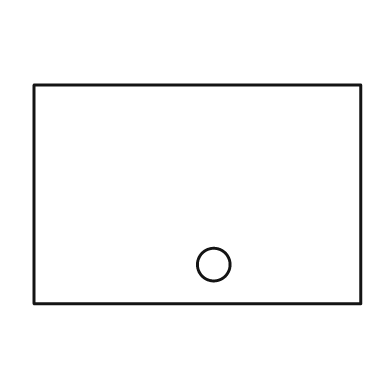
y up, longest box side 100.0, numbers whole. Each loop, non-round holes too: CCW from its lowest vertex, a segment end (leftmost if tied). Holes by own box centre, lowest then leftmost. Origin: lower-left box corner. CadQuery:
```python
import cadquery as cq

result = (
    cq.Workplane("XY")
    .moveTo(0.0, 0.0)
    .lineTo(100.0, 0.0)
    .lineTo(100.0, 67.0)
    .lineTo(0.0, 67.0)
    .close()
    .moveTo(55.0, 12.0)
    .circle(5.0)
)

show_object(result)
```